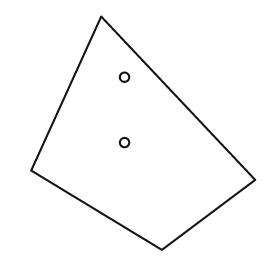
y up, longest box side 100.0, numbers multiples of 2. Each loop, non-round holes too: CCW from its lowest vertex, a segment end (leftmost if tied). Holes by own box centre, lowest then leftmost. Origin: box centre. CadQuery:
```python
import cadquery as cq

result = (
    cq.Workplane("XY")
    .moveTo(8.0, -50.0)
    .lineTo(48.0, -20.0)
    .lineTo(-18.0, 50.0)
    .lineTo(-48.0, -16.0)
    .close()
    .moveTo(-8.0, -4.0)
    .circle(2.0)
    .moveTo(-8.0, 24.0)
    .circle(2.0)
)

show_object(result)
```